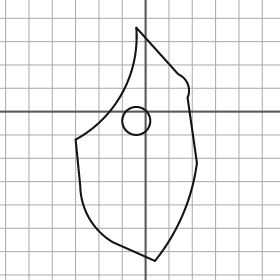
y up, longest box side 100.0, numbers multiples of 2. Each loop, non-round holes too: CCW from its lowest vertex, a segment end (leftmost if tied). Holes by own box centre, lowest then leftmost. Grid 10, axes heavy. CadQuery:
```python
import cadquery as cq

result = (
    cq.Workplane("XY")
    .moveTo(4.0, -64.0)
    .threePointArc((16.0, -44.0), (22.0, -22.0))
    .lineTo(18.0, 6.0)
    .threePointArc((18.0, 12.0), (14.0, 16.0))
    .lineTo(-4.0, 36.0)
    .threePointArc((-10.0, 8.0), (-30.0, -12.0))
    .lineTo(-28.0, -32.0)
    .threePointArc((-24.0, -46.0), (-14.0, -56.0))
    .close()
    .moveTo(-4.0, -4.0)
    .circle(6.0)
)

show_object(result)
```